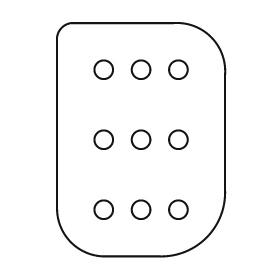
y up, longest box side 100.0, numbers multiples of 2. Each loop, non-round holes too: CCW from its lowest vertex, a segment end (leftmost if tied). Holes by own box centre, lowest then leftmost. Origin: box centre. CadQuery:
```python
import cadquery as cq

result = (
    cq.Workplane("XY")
    .moveTo(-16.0, -50.0)
    .lineTo(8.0, -50.0)
    .threePointArc((28.0, -42.0), (36.0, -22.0))
    .lineTo(36.0, 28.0)
    .threePointArc((30.0, 44.0), (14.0, 50.0))
    .lineTo(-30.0, 50.0)
    .threePointArc((-34.0, 48.0), (-36.0, 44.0))
    .lineTo(-36.0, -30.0)
    .threePointArc((-30.0, -44.0), (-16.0, -50.0))
    .close()
    .moveTo(-16.0, -30.0)
    .circle(4.0)
    .moveTo(0.0, -30.0)
    .circle(4.0)
    .moveTo(16.0, -30.0)
    .circle(4.0)
    .moveTo(-16.0, 0.0)
    .circle(4.0)
    .moveTo(0.0, 0.0)
    .circle(4.0)
    .moveTo(16.0, 0.0)
    .circle(4.0)
    .moveTo(-16.0, 30.0)
    .circle(4.0)
    .moveTo(0.0, 30.0)
    .circle(4.0)
    .moveTo(16.0, 30.0)
    .circle(4.0)
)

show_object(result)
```